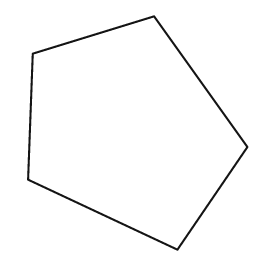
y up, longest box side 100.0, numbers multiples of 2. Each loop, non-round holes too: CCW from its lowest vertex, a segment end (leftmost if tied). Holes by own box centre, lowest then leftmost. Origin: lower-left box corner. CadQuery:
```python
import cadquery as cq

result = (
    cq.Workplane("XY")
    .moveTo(64.0, 0.0)
    .lineTo(94.0, 44.0)
    .lineTo(54.0, 100.0)
    .lineTo(2.0, 84.0)
    .lineTo(0.0, 30.0)
    .close()
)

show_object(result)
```